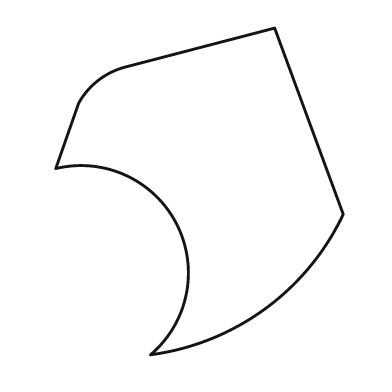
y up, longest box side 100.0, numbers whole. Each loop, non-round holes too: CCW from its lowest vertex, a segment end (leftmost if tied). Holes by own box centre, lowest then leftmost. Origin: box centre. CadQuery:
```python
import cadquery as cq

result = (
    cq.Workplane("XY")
    .moveTo(-15.0, -50.0)
    .threePointArc((20.0, -36.0), (44.0, -7.0))
    .lineTo(23.0, 50.0)
    .lineTo(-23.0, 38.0)
    .threePointArc((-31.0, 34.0), (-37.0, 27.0))
    .lineTo(-44.0, 7.0)
    .threePointArc((-7.0, -10.0), (-15.0, -50.0))
    .close()
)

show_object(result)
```